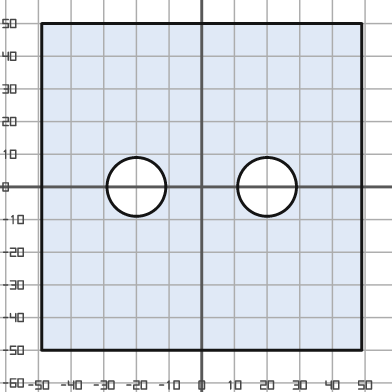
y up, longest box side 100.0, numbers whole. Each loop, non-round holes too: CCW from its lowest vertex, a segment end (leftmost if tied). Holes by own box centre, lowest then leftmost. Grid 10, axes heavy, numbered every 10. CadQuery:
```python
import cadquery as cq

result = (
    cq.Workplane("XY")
    .moveTo(-49.0, -50.0)
    .lineTo(49.0, -50.0)
    .lineTo(49.0, 50.0)
    .lineTo(-49.0, 50.0)
    .close()
    .moveTo(-20.0, 0.0)
    .circle(9.0)
    .moveTo(20.0, 0.0)
    .circle(9.0)
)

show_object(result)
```